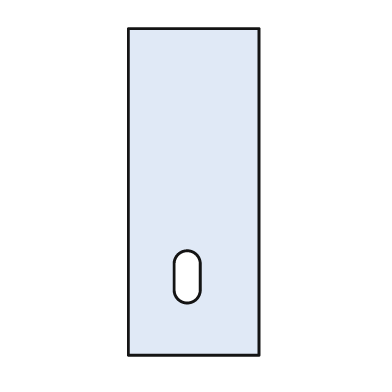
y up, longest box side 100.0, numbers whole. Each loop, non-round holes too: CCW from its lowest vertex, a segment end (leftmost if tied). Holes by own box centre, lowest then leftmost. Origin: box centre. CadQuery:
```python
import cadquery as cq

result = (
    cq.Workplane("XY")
    .moveTo(-20.0, -50.0)
    .lineTo(20.0, -50.0)
    .lineTo(20.0, 50.0)
    .lineTo(-20.0, 50.0)
    .close()
    .moveTo(-6.0, -30.0)
    .threePointArc((-2.0, -34.0), (2.0, -30.0))
    .lineTo(2.0, -22.0)
    .threePointArc((-2.0, -18.0), (-6.0, -22.0))
    .close()
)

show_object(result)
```